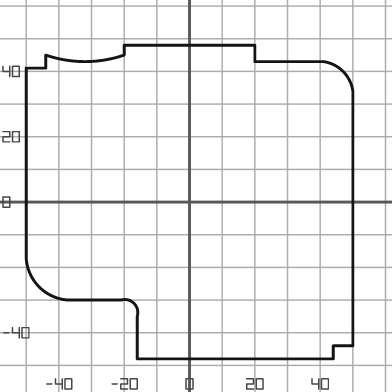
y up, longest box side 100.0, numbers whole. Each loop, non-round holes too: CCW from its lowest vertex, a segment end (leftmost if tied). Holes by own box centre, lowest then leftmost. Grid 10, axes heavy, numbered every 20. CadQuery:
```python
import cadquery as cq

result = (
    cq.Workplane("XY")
    .moveTo(-16.0, -48.0)
    .lineTo(44.0, -48.0)
    .lineTo(44.0, -44.0)
    .lineTo(50.0, -44.0)
    .lineTo(50.0, 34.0)
    .threePointArc((47.0, 40.0), (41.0, 43.0))
    .lineTo(20.0, 43.0)
    .lineTo(20.0, 48.0)
    .lineTo(-20.0, 48.0)
    .lineTo(-20.0, 45.0)
    .threePointArc((-32.0, 43.0), (-44.0, 45.0))
    .lineTo(-44.0, 41.0)
    .lineTo(-50.0, 41.0)
    .lineTo(-50.0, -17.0)
    .threePointArc((-46.0, -26.0), (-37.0, -30.0))
    .lineTo(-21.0, -30.0)
    .threePointArc((-17.0, -31.0), (-16.0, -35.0))
    .close()
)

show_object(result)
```